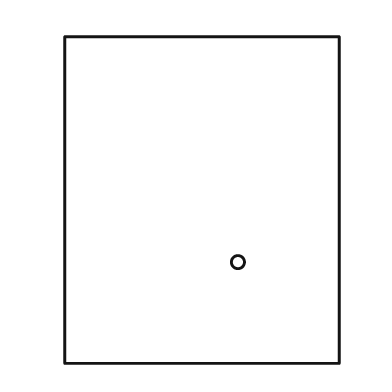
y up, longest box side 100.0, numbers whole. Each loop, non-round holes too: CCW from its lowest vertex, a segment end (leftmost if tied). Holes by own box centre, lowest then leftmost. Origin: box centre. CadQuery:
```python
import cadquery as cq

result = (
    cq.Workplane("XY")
    .moveTo(-42.0, -50.0)
    .lineTo(42.0, -50.0)
    .lineTo(42.0, 50.0)
    .lineTo(-42.0, 50.0)
    .close()
    .moveTo(11.0, -19.0)
    .circle(2.0)
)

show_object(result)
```